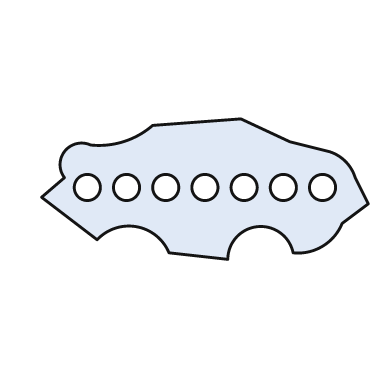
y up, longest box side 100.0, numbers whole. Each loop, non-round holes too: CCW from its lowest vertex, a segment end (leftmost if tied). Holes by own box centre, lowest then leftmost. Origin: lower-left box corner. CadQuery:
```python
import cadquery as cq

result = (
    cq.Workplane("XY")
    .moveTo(57.0, 0.0)
    .threePointArc((66.0, 10.0), (77.0, 2.0))
    .threePointArc((86.0, 4.0), (92.0, 11.0))
    .lineTo(100.0, 17.0)
    .lineTo(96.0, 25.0)
    .threePointArc((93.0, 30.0), (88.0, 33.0))
    .lineTo(76.0, 36.0)
    .lineTo(61.0, 43.0)
    .lineTo(34.0, 41.0)
    .threePointArc((25.0, 36.0), (15.0, 35.0))
    .threePointArc((7.0, 33.0), (7.0, 25.0))
    .lineTo(0.0, 19.0)
    .lineTo(17.0, 6.0)
    .threePointArc((29.0, 10.0), (39.0, 2.0))
    .close()
    .moveTo(14.0, 22.0)
    .circle(4.0)
    .moveTo(26.0, 22.0)
    .circle(4.0)
    .moveTo(38.0, 22.0)
    .circle(4.0)
    .moveTo(50.0, 22.0)
    .circle(4.0)
    .moveTo(62.0, 22.0)
    .circle(4.0)
    .moveTo(74.0, 22.0)
    .circle(4.0)
    .moveTo(86.0, 22.0)
    .circle(4.0)
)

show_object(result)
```